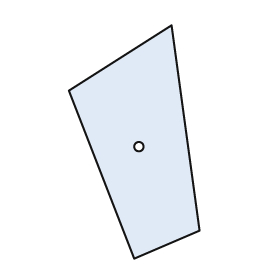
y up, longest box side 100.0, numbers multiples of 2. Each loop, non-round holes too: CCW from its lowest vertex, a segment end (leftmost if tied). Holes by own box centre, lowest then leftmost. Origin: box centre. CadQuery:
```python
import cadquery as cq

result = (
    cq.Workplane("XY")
    .moveTo(0.0, -50.0)
    .lineTo(28.0, -38.0)
    .lineTo(16.0, 50.0)
    .lineTo(-28.0, 22.0)
    .close()
    .moveTo(2.0, -2.0)
    .circle(2.0)
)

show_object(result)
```